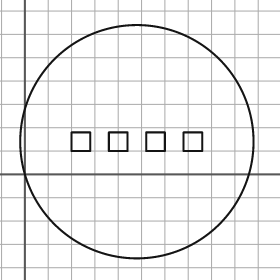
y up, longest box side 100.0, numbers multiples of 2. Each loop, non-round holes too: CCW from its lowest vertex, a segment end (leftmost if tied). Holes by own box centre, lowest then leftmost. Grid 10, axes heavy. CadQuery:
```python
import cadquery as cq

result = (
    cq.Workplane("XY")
    .moveTo(48.0, 14.0)
    .circle(50.0)
    .moveTo(20.0, 10.0)
    .lineTo(28.0, 10.0)
    .lineTo(28.0, 18.0)
    .lineTo(20.0, 18.0)
    .close()
    .moveTo(36.0, 10.0)
    .lineTo(44.0, 10.0)
    .lineTo(44.0, 18.0)
    .lineTo(36.0, 18.0)
    .close()
    .moveTo(52.0, 10.0)
    .lineTo(60.0, 10.0)
    .lineTo(60.0, 18.0)
    .lineTo(52.0, 18.0)
    .close()
    .moveTo(68.0, 10.0)
    .lineTo(76.0, 10.0)
    .lineTo(76.0, 18.0)
    .lineTo(68.0, 18.0)
    .close()
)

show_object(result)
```